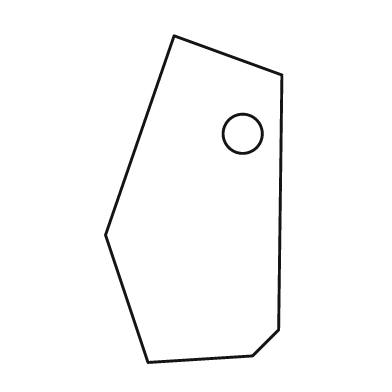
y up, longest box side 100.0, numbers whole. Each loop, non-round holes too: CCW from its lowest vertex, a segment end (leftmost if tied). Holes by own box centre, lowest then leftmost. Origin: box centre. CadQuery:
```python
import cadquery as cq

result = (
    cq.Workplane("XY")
    .moveTo(-14.0, -50.0)
    .lineTo(18.0, -48.0)
    .lineTo(26.0, -40.0)
    .lineTo(27.0, 38.0)
    .lineTo(-6.0, 50.0)
    .lineTo(-27.0, -11.0)
    .close()
    .moveTo(15.0, 20.0)
    .circle(6.0)
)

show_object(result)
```